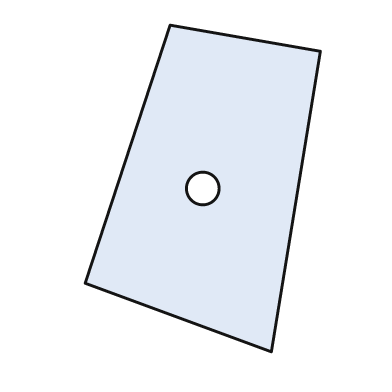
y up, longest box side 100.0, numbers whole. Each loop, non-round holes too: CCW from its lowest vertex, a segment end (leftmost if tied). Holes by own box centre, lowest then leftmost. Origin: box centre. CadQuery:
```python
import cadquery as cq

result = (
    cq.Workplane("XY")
    .moveTo(21.0, -50.0)
    .lineTo(36.0, 42.0)
    .lineTo(-10.0, 50.0)
    .lineTo(-36.0, -29.0)
    .close()
    .moveTo(0.0, 0.0)
    .circle(5.0)
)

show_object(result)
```